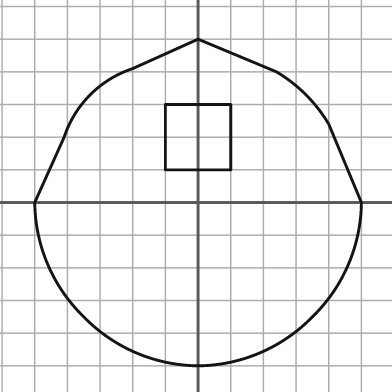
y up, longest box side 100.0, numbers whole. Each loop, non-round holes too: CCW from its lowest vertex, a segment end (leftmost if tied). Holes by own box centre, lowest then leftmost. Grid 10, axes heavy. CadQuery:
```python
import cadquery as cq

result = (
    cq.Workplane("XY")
    .moveTo(0.0, -50.0)
    .threePointArc((19.0, -46.0), (35.0, -35.0))
    .threePointArc((46.0, -19.0), (50.0, 0.0))
    .lineTo(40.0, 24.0)
    .threePointArc((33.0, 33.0), (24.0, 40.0))
    .lineTo(0.0, 50.0)
    .lineTo(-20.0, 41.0)
    .threePointArc((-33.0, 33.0), (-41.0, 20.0))
    .lineTo(-50.0, 0.0)
    .threePointArc((-46.0, -19.0), (-35.0, -35.0))
    .threePointArc((-19.0, -46.0), (0.0, -50.0))
    .close()
    .moveTo(-10.0, 10.0)
    .lineTo(10.0, 10.0)
    .lineTo(10.0, 30.0)
    .lineTo(-10.0, 30.0)
    .close()
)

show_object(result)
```